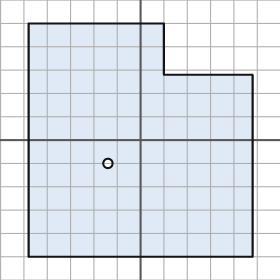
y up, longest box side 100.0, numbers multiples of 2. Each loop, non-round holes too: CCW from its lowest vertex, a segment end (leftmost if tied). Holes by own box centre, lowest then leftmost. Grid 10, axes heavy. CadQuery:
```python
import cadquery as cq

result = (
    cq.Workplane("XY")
    .moveTo(-48.0, -50.0)
    .lineTo(48.0, -50.0)
    .lineTo(48.0, 28.0)
    .lineTo(10.0, 28.0)
    .lineTo(10.0, 50.0)
    .lineTo(-48.0, 50.0)
    .close()
    .moveTo(-14.0, -10.0)
    .circle(2.0)
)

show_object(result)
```